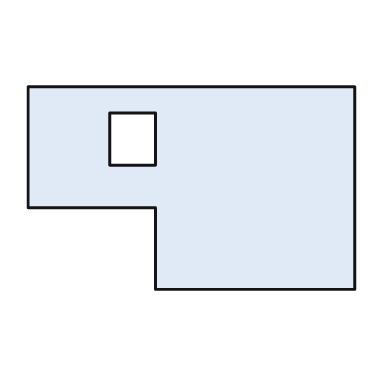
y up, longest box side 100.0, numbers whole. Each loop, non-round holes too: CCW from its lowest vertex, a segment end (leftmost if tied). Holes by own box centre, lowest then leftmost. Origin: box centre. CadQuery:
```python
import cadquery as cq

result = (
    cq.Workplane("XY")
    .moveTo(-11.0, -31.0)
    .lineTo(50.0, -31.0)
    .lineTo(50.0, 31.0)
    .lineTo(-50.0, 31.0)
    .lineTo(-50.0, -6.0)
    .lineTo(-11.0, -6.0)
    .close()
    .moveTo(-25.0, 7.0)
    .lineTo(-11.0, 7.0)
    .lineTo(-11.0, 23.0)
    .lineTo(-25.0, 23.0)
    .close()
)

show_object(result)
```